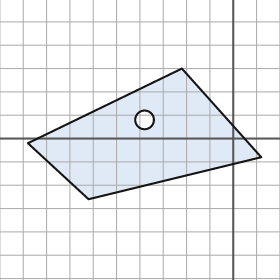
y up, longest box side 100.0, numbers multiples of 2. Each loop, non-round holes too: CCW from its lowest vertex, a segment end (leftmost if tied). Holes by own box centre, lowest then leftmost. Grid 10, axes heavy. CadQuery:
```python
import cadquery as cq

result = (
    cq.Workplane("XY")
    .moveTo(-62.0, -26.0)
    .lineTo(12.0, -8.0)
    .lineTo(-22.0, 30.0)
    .lineTo(-88.0, -2.0)
    .close()
    .moveTo(-38.0, 8.0)
    .circle(4.0)
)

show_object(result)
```